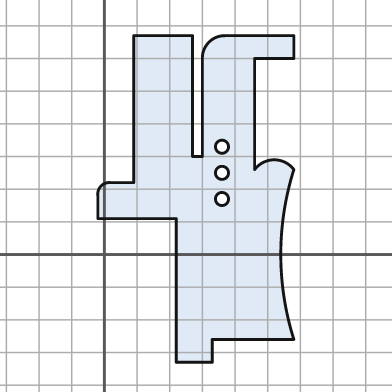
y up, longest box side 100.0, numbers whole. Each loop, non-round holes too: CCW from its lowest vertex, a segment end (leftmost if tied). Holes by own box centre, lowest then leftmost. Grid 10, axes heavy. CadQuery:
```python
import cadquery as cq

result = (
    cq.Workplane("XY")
    .moveTo(22.0, -33.0)
    .lineTo(33.0, -33.0)
    .lineTo(33.0, -26.0)
    .lineTo(58.0, -26.0)
    .threePointArc((54.0, 0.0), (58.0, 26.0))
    .threePointArc((52.0, 29.0), (46.0, 26.0))
    .lineTo(46.0, 60.0)
    .lineTo(58.0, 60.0)
    .lineTo(58.0, 67.0)
    .lineTo(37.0, 67.0)
    .threePointArc((32.0, 65.0), (30.0, 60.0))
    .lineTo(30.0, 30.0)
    .lineTo(27.0, 30.0)
    .lineTo(27.0, 67.0)
    .lineTo(9.0, 67.0)
    .lineTo(9.0, 22.0)
    .lineTo(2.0, 22.0)
    .threePointArc((-1.0, 21.0), (-2.0, 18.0))
    .lineTo(-2.0, 11.0)
    .lineTo(22.0, 11.0)
    .close()
    .moveTo(36.0, 17.0)
    .circle(2.0)
    .moveTo(36.0, 25.0)
    .circle(2.0)
    .moveTo(36.0, 33.0)
    .circle(2.0)
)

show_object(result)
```